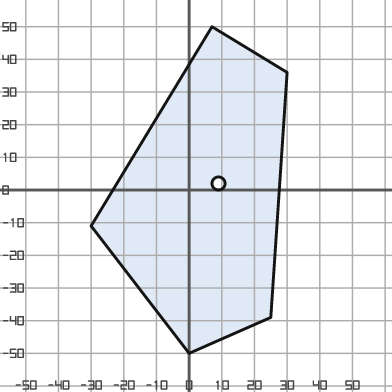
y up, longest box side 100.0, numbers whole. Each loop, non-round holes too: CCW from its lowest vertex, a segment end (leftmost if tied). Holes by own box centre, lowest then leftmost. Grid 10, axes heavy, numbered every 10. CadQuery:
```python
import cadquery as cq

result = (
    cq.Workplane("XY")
    .moveTo(0.0, -50.0)
    .lineTo(25.0, -39.0)
    .lineTo(30.0, 36.0)
    .lineTo(7.0, 50.0)
    .lineTo(-30.0, -11.0)
    .close()
    .moveTo(9.0, 2.0)
    .circle(2.0)
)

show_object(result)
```